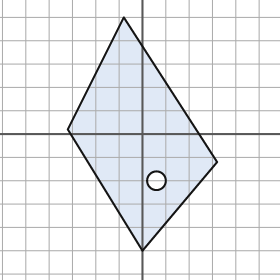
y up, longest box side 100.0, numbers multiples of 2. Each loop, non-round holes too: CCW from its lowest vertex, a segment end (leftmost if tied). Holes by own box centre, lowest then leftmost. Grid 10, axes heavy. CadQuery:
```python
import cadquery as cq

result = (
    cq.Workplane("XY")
    .moveTo(0.0, -50.0)
    .lineTo(32.0, -12.0)
    .lineTo(-8.0, 50.0)
    .lineTo(-32.0, 2.0)
    .close()
    .moveTo(6.0, -20.0)
    .circle(4.0)
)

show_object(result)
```